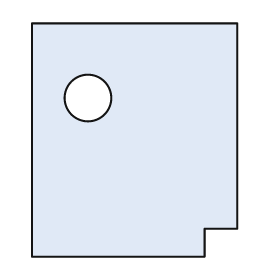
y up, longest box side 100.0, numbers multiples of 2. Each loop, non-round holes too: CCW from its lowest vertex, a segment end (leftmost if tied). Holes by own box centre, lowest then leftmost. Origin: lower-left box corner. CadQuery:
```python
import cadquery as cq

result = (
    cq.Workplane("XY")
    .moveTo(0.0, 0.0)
    .lineTo(74.0, 0.0)
    .lineTo(74.0, 12.0)
    .lineTo(88.0, 12.0)
    .lineTo(88.0, 100.0)
    .lineTo(0.0, 100.0)
    .close()
    .moveTo(24.0, 68.0)
    .circle(10.0)
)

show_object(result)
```